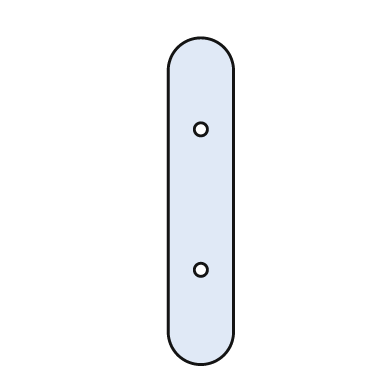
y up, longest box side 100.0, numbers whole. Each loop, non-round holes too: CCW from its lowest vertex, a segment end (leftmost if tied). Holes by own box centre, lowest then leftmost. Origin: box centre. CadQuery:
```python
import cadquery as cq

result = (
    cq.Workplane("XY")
    .moveTo(-10.0, -40.0)
    .threePointArc((0.0, -50.0), (10.0, -40.0))
    .lineTo(10.0, 40.0)
    .threePointArc((0.0, 50.0), (-10.0, 40.0))
    .close()
    .moveTo(0.0, -21.0)
    .circle(2.0)
    .moveTo(0.0, 22.0)
    .circle(2.0)
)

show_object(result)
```